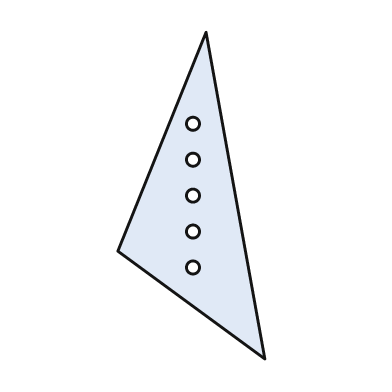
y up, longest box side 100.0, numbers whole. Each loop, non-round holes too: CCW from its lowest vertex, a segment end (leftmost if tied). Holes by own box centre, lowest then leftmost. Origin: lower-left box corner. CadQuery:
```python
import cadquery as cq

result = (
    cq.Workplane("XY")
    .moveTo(45.0, 0.0)
    .lineTo(27.0, 100.0)
    .lineTo(0.0, 33.0)
    .close()
    .moveTo(23.0, 28.0)
    .circle(2.0)
    .moveTo(23.0, 39.0)
    .circle(2.0)
    .moveTo(23.0, 50.0)
    .circle(2.0)
    .moveTo(23.0, 61.0)
    .circle(2.0)
    .moveTo(23.0, 72.0)
    .circle(2.0)
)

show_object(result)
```